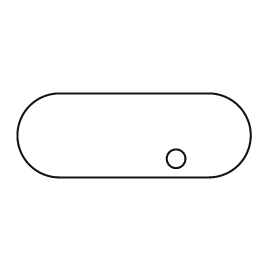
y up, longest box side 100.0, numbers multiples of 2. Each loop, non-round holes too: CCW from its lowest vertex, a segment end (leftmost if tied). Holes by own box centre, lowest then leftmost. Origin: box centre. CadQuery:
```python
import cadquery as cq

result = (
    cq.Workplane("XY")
    .moveTo(-32.0, -18.0)
    .lineTo(32.0, -18.0)
    .threePointArc((50.0, 0.0), (32.0, 18.0))
    .lineTo(-32.0, 18.0)
    .threePointArc((-50.0, 0.0), (-32.0, -18.0))
    .close()
    .moveTo(18.0, -10.0)
    .circle(4.0)
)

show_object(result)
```